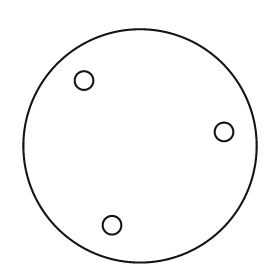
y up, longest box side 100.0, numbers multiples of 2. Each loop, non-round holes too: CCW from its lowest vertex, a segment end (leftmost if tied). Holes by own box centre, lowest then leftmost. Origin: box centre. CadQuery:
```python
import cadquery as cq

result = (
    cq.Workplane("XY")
    .moveTo(0.0, 0.0)
    .circle(50.0)
    .moveTo(-12.0, -34.0)
    .circle(4.0)
    .moveTo(36.0, 6.0)
    .circle(4.0)
    .moveTo(-24.0, 28.0)
    .circle(4.0)
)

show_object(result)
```